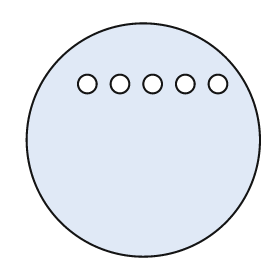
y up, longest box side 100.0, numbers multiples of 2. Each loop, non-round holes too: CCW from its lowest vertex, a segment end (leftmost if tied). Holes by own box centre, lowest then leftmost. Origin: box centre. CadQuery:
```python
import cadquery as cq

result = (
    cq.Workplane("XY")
    .moveTo(0.0, 0.0)
    .circle(50.0)
    .moveTo(-24.0, 24.0)
    .circle(4.0)
    .moveTo(-10.0, 24.0)
    .circle(4.0)
    .moveTo(4.0, 24.0)
    .circle(4.0)
    .moveTo(18.0, 24.0)
    .circle(4.0)
    .moveTo(32.0, 24.0)
    .circle(4.0)
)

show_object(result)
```